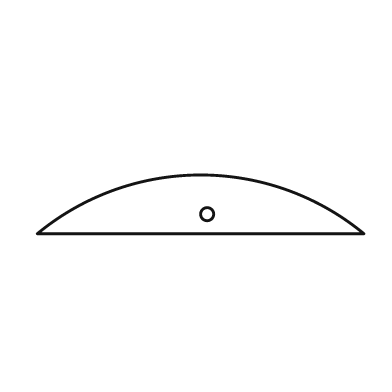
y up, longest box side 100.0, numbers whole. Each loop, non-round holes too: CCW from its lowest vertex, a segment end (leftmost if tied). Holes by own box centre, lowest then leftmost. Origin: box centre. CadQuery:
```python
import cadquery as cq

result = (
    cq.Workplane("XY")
    .moveTo(-50.0, -9.0)
    .lineTo(50.0, -9.0)
    .threePointArc((0.0, 9.0), (-50.0, -9.0))
    .close()
    .moveTo(2.0, -3.0)
    .circle(2.0)
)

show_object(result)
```